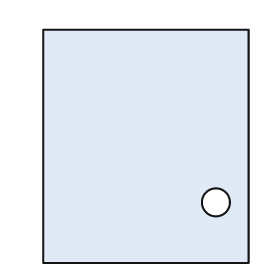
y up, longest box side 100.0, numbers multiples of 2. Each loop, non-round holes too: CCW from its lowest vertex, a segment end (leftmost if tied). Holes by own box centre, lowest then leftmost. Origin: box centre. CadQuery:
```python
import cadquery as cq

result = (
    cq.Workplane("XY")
    .moveTo(-44.0, -50.0)
    .lineTo(44.0, -50.0)
    .lineTo(44.0, 50.0)
    .lineTo(-44.0, 50.0)
    .close()
    .moveTo(30.0, -24.0)
    .circle(6.0)
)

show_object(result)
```